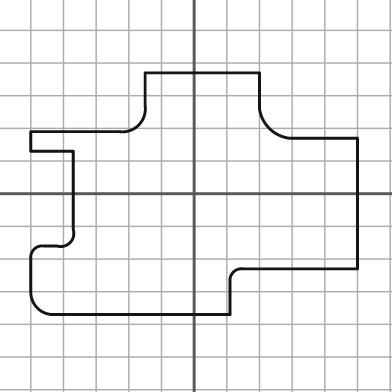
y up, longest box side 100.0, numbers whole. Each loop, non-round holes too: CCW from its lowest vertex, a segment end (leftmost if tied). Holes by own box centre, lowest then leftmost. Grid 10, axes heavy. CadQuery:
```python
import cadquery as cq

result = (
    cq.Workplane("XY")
    .moveTo(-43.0, -37.0)
    .lineTo(11.0, -37.0)
    .lineTo(11.0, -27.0)
    .threePointArc((12.0, -24.0), (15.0, -23.0))
    .lineTo(50.0, -23.0)
    .lineTo(50.0, 17.0)
    .lineTo(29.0, 17.0)
    .threePointArc((23.0, 20.0), (20.0, 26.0))
    .lineTo(20.0, 37.0)
    .lineTo(-15.0, 37.0)
    .lineTo(-15.0, 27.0)
    .threePointArc((-17.0, 21.0), (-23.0, 19.0))
    .lineTo(-50.0, 19.0)
    .lineTo(-50.0, 13.0)
    .lineTo(-37.0, 13.0)
    .lineTo(-37.0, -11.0)
    .threePointArc((-38.0, -15.0), (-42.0, -16.0))
    .lineTo(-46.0, -16.0)
    .threePointArc((-49.0, -17.0), (-50.0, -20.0))
    .lineTo(-50.0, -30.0)
    .threePointArc((-48.0, -35.0), (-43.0, -37.0))
    .close()
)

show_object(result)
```